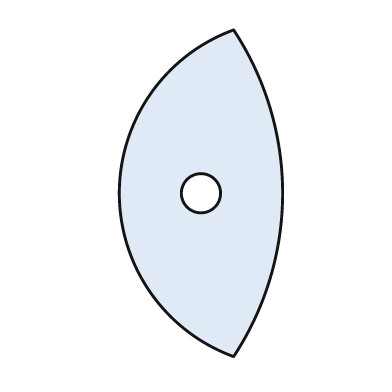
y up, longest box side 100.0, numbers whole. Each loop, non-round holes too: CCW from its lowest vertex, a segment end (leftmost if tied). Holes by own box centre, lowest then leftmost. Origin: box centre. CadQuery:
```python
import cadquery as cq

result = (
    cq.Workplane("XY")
    .moveTo(10.0, -50.0)
    .threePointArc((25.0, 0.0), (10.0, 50.0))
    .threePointArc((-25.0, 0.0), (10.0, -50.0))
    .close()
    .moveTo(0.0, 0.0)
    .circle(6.0)
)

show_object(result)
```